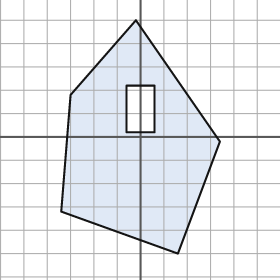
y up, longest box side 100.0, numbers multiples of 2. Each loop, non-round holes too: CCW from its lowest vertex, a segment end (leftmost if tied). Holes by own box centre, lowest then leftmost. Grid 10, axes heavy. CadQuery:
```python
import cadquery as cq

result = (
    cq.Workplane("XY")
    .moveTo(16.0, -50.0)
    .lineTo(34.0, -2.0)
    .lineTo(-2.0, 50.0)
    .lineTo(-30.0, 18.0)
    .lineTo(-34.0, -32.0)
    .close()
    .moveTo(-6.0, 2.0)
    .lineTo(6.0, 2.0)
    .lineTo(6.0, 22.0)
    .lineTo(-6.0, 22.0)
    .close()
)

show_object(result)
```